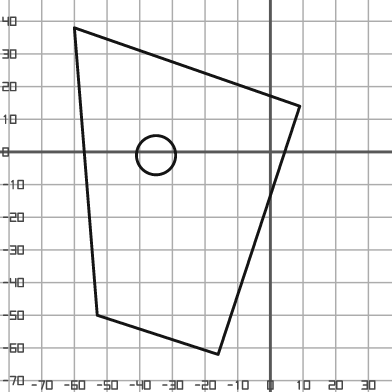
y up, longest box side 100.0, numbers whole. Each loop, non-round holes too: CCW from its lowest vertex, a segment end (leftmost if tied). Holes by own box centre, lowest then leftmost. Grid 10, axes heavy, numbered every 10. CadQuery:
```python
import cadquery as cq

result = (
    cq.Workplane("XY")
    .moveTo(-16.0, -62.0)
    .lineTo(9.0, 14.0)
    .lineTo(-60.0, 38.0)
    .lineTo(-53.0, -50.0)
    .close()
    .moveTo(-35.0, -1.0)
    .circle(6.0)
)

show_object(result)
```